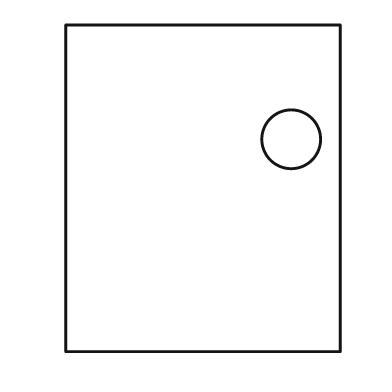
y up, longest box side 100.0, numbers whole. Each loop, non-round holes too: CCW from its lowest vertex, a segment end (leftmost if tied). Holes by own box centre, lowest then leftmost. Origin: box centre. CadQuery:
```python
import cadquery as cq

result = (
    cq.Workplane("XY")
    .moveTo(-42.0, -50.0)
    .lineTo(42.0, -50.0)
    .lineTo(42.0, 50.0)
    .lineTo(-42.0, 50.0)
    .close()
    .moveTo(27.0, 15.0)
    .circle(9.0)
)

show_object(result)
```